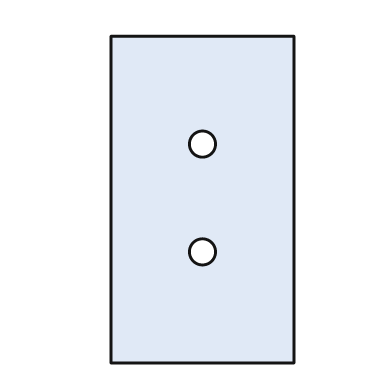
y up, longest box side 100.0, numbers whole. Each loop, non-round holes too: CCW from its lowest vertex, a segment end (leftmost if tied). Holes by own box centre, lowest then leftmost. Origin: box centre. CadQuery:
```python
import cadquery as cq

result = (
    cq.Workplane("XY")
    .moveTo(-28.0, -50.0)
    .lineTo(28.0, -50.0)
    .lineTo(28.0, 50.0)
    .lineTo(-28.0, 50.0)
    .close()
    .moveTo(0.0, -16.0)
    .circle(4.0)
    .moveTo(0.0, 17.0)
    .circle(4.0)
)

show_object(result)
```